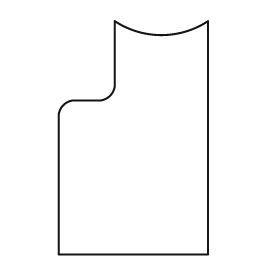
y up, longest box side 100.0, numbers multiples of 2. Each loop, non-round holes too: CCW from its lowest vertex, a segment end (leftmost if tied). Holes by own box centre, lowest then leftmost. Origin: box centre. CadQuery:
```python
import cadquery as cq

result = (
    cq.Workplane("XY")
    .moveTo(-32.0, -50.0)
    .lineTo(32.0, -50.0)
    .lineTo(32.0, 50.0)
    .threePointArc((12.0, 44.0), (-8.0, 50.0))
    .lineTo(-8.0, 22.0)
    .threePointArc((-10.0, 18.0), (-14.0, 16.0))
    .lineTo(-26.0, 16.0)
    .threePointArc((-30.0, 14.0), (-32.0, 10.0))
    .close()
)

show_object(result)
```